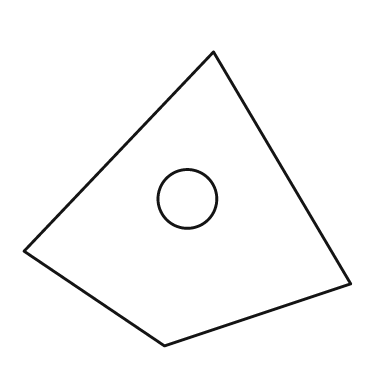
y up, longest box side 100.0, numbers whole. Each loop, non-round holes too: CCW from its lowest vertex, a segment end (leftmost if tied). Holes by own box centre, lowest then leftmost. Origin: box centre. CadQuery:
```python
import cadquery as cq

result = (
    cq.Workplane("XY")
    .moveTo(-7.0, -45.0)
    .lineTo(50.0, -26.0)
    .lineTo(8.0, 45.0)
    .lineTo(-50.0, -16.0)
    .close()
    .moveTo(0.0, 0.0)
    .circle(9.0)
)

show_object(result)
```